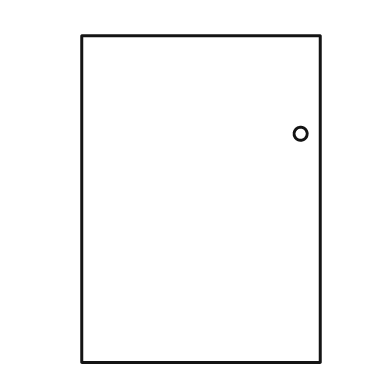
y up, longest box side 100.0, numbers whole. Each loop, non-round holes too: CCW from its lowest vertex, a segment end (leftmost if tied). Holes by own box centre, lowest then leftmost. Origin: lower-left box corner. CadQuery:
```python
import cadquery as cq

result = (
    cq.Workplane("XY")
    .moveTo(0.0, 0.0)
    .lineTo(73.0, 0.0)
    .lineTo(73.0, 100.0)
    .lineTo(0.0, 100.0)
    .close()
    .moveTo(67.0, 70.0)
    .circle(2.0)
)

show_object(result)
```